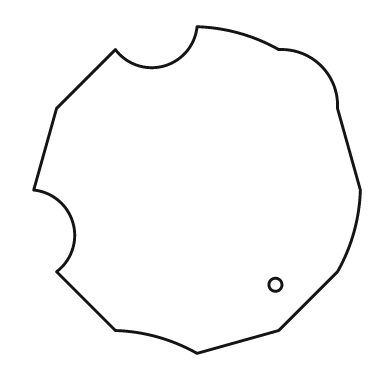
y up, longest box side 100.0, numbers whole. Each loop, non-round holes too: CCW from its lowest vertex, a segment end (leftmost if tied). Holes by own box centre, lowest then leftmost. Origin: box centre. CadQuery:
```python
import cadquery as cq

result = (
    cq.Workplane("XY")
    .moveTo(0.0, -50.0)
    .lineTo(25.0, -43.0)
    .lineTo(43.0, -25.0)
    .threePointArc((48.0, -13.0), (50.0, 0.0))
    .lineTo(43.0, 25.0)
    .threePointArc((38.0, 38.0), (25.0, 43.0))
    .threePointArc((13.0, 48.0), (0.0, 50.0))
    .threePointArc((-10.0, 38.0), (-25.0, 43.0))
    .lineTo(-43.0, 25.0)
    .lineTo(-50.0, 0.0)
    .threePointArc((-38.0, -10.0), (-43.0, -25.0))
    .lineTo(-25.0, -43.0)
    .threePointArc((-12.0, -45.0), (0.0, -50.0))
    .close()
    .moveTo(24.0, -29.0)
    .circle(2.0)
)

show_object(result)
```